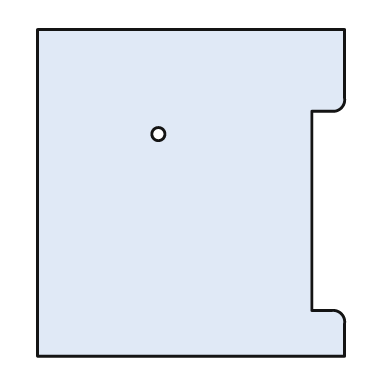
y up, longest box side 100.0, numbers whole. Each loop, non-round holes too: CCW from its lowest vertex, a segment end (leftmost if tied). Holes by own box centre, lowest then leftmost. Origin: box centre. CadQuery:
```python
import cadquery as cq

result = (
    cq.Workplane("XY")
    .moveTo(-47.0, -50.0)
    .lineTo(47.0, -50.0)
    .lineTo(47.0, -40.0)
    .threePointArc((46.0, -37.0), (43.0, -36.0))
    .lineTo(37.0, -36.0)
    .lineTo(37.0, 25.0)
    .lineTo(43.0, 25.0)
    .threePointArc((46.0, 26.0), (47.0, 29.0))
    .lineTo(47.0, 50.0)
    .lineTo(-47.0, 50.0)
    .close()
    .moveTo(-10.0, 18.0)
    .circle(2.0)
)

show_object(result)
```